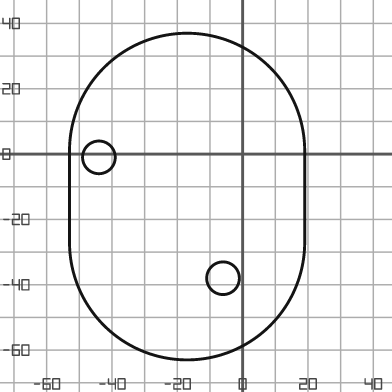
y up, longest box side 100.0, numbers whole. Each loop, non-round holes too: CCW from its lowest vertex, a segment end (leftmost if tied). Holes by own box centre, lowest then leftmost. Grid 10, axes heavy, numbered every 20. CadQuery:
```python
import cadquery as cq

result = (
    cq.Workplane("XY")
    .moveTo(-53.0, -27.0)
    .threePointArc((-17.0, -63.0), (19.0, -27.0))
    .lineTo(19.0, 1.0)
    .threePointArc((-17.0, 37.0), (-53.0, 1.0))
    .close()
    .moveTo(-6.0, -38.0)
    .circle(5.0)
    .moveTo(-44.0, -1.0)
    .circle(5.0)
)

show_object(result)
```